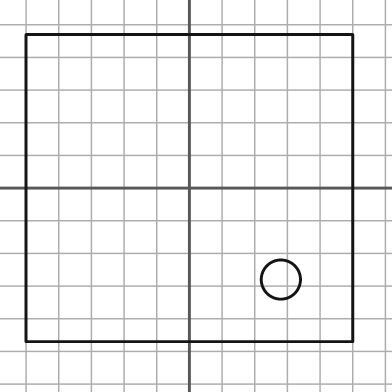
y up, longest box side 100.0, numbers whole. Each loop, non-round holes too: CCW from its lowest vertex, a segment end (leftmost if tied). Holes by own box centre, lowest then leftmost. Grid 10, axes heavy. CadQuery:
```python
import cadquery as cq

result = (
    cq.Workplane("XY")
    .moveTo(-50.0, -47.0)
    .lineTo(50.0, -47.0)
    .lineTo(50.0, 47.0)
    .lineTo(-50.0, 47.0)
    .close()
    .moveTo(28.0, -28.0)
    .circle(6.0)
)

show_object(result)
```